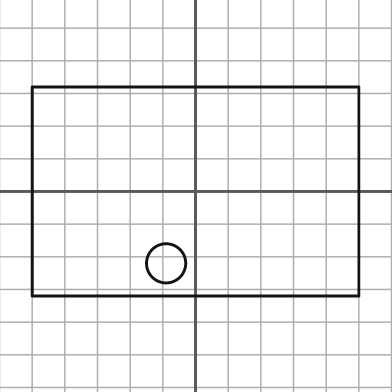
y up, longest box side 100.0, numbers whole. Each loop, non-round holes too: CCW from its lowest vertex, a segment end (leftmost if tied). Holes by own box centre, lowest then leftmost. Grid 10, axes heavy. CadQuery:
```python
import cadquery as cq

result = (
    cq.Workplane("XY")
    .moveTo(-50.0, -32.0)
    .lineTo(50.0, -32.0)
    .lineTo(50.0, 32.0)
    .lineTo(-50.0, 32.0)
    .close()
    .moveTo(-9.0, -22.0)
    .circle(6.0)
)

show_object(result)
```